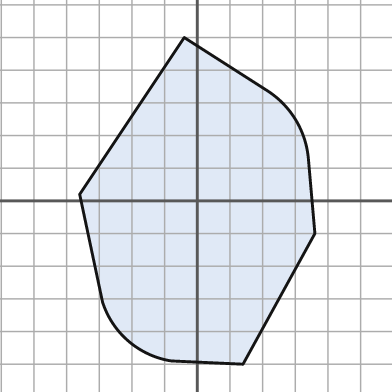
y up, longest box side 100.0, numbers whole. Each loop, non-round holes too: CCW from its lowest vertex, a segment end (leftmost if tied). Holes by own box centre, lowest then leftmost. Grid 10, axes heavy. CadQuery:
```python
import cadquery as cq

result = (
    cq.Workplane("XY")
    .moveTo(14.0, -50.0)
    .lineTo(36.0, -10.0)
    .lineTo(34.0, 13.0)
    .threePointArc((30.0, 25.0), (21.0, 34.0))
    .lineTo(-4.0, 50.0)
    .lineTo(-36.0, 2.0)
    .lineTo(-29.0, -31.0)
    .threePointArc((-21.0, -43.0), (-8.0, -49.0))
    .close()
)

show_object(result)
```